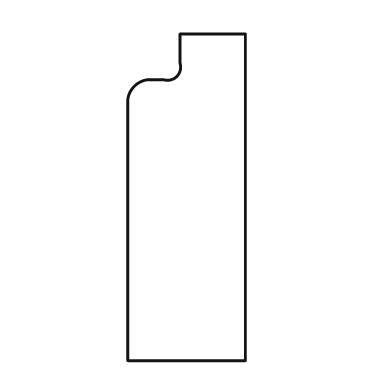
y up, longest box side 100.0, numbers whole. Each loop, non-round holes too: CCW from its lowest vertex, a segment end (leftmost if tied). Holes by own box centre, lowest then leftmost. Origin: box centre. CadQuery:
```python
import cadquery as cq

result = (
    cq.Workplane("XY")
    .moveTo(-18.0, -50.0)
    .lineTo(18.0, -50.0)
    .lineTo(18.0, 50.0)
    .lineTo(-2.0, 50.0)
    .lineTo(-2.0, 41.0)
    .threePointArc((-3.0, 37.0), (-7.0, 36.0))
    .lineTo(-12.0, 36.0)
    .threePointArc((-16.0, 34.0), (-18.0, 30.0))
    .close()
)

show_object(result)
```